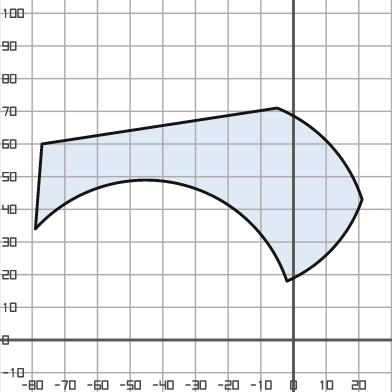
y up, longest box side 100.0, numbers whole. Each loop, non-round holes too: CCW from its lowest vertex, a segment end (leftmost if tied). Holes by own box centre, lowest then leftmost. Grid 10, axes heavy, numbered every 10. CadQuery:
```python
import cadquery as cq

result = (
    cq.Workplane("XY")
    .moveTo(-2.0, 18.0)
    .threePointArc((12.0, 28.0), (21.0, 43.0))
    .threePointArc((11.0, 60.0), (-5.0, 71.0))
    .lineTo(-77.0, 60.0)
    .lineTo(-79.0, 34.0)
    .threePointArc((-36.0, 48.0), (-2.0, 18.0))
    .close()
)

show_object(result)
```